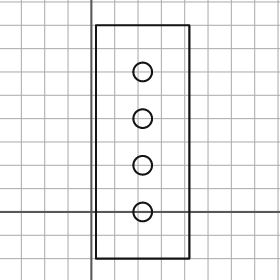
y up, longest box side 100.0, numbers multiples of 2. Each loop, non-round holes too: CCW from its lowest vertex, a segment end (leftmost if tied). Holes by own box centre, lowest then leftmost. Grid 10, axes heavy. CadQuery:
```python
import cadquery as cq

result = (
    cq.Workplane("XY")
    .moveTo(2.0, -20.0)
    .lineTo(42.0, -20.0)
    .lineTo(42.0, 80.0)
    .lineTo(2.0, 80.0)
    .close()
    .moveTo(22.0, 0.0)
    .circle(4.0)
    .moveTo(22.0, 20.0)
    .circle(4.0)
    .moveTo(22.0, 40.0)
    .circle(4.0)
    .moveTo(22.0, 60.0)
    .circle(4.0)
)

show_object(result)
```